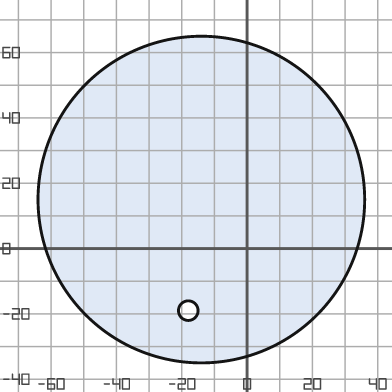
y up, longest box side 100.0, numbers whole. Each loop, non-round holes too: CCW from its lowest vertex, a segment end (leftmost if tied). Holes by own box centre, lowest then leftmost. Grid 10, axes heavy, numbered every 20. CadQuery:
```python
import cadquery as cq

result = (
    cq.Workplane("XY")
    .moveTo(-14.0, 15.0)
    .circle(50.0)
    .moveTo(-18.0, -19.0)
    .circle(3.0)
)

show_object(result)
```